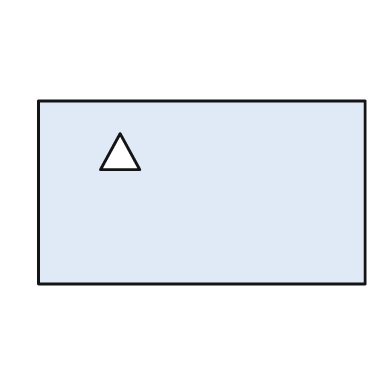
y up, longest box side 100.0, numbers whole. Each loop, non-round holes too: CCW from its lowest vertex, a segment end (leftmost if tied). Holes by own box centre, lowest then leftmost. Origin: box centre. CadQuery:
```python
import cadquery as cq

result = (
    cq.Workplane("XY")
    .moveTo(-50.0, -28.0)
    .lineTo(50.0, -28.0)
    .lineTo(50.0, 28.0)
    .lineTo(-50.0, 28.0)
    .close()
    .moveTo(-31.0, 7.0)
    .lineTo(-19.0, 7.0)
    .lineTo(-25.0, 18.0)
    .close()
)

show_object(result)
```